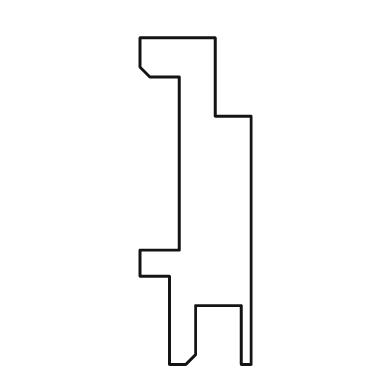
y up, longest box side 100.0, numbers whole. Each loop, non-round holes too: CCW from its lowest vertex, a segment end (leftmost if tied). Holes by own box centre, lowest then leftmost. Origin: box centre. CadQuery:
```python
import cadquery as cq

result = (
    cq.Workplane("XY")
    .moveTo(-8.0, -50.0)
    .lineTo(-3.0, -50.0)
    .lineTo(0.0, -47.0)
    .lineTo(0.0, -32.0)
    .lineTo(14.0, -32.0)
    .lineTo(14.0, -50.0)
    .lineTo(17.0, -50.0)
    .lineTo(17.0, 26.0)
    .lineTo(6.0, 26.0)
    .lineTo(6.0, 50.0)
    .lineTo(-17.0, 50.0)
    .lineTo(-17.0, 41.0)
    .lineTo(-14.0, 38.0)
    .lineTo(-5.0, 38.0)
    .lineTo(-5.0, -15.0)
    .lineTo(-17.0, -15.0)
    .lineTo(-17.0, -23.0)
    .lineTo(-8.0, -23.0)
    .close()
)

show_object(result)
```